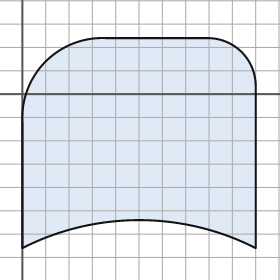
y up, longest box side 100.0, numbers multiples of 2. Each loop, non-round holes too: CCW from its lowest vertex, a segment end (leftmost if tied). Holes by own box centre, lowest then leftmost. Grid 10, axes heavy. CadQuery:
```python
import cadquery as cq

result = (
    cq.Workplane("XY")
    .moveTo(0.0, -66.0)
    .threePointArc((50.0, -54.0), (100.0, -66.0))
    .lineTo(100.0, 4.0)
    .threePointArc((94.0, 18.0), (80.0, 24.0))
    .lineTo(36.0, 24.0)
    .threePointArc((10.0, 14.0), (0.0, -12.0))
    .close()
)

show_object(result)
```